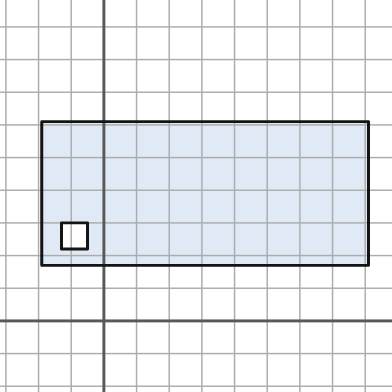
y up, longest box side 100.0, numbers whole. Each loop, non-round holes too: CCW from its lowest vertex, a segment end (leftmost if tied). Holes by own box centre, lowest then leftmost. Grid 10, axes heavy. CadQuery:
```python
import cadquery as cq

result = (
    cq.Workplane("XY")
    .moveTo(-19.0, 17.0)
    .lineTo(81.0, 17.0)
    .lineTo(81.0, 61.0)
    .lineTo(-19.0, 61.0)
    .close()
    .moveTo(-13.0, 22.0)
    .lineTo(-5.0, 22.0)
    .lineTo(-5.0, 30.0)
    .lineTo(-13.0, 30.0)
    .close()
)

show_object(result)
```